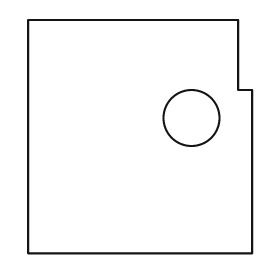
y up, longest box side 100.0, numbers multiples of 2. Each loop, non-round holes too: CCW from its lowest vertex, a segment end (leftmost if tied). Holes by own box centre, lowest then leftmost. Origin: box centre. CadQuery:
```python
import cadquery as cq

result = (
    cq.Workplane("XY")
    .moveTo(-48.0, -50.0)
    .lineTo(48.0, -50.0)
    .lineTo(48.0, 20.0)
    .lineTo(42.0, 20.0)
    .lineTo(42.0, 50.0)
    .lineTo(-48.0, 50.0)
    .close()
    .moveTo(22.0, 8.0)
    .circle(12.0)
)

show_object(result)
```